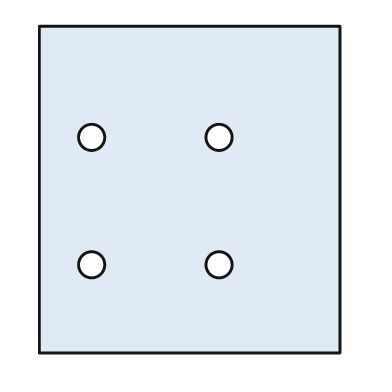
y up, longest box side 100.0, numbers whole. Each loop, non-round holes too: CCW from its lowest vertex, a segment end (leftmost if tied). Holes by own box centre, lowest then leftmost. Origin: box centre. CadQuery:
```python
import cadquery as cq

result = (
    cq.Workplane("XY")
    .moveTo(-46.0, -50.0)
    .lineTo(46.0, -50.0)
    .lineTo(46.0, 50.0)
    .lineTo(-46.0, 50.0)
    .close()
    .moveTo(-30.0, -23.0)
    .circle(4.0)
    .moveTo(9.0, -23.0)
    .circle(4.0)
    .moveTo(-30.0, 16.0)
    .circle(4.0)
    .moveTo(9.0, 16.0)
    .circle(4.0)
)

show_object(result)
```